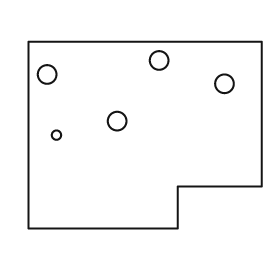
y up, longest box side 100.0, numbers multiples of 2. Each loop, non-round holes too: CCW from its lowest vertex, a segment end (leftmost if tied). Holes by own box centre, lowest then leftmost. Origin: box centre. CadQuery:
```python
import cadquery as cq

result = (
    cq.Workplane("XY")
    .moveTo(-50.0, -40.0)
    .lineTo(14.0, -40.0)
    .lineTo(14.0, -22.0)
    .lineTo(50.0, -22.0)
    .lineTo(50.0, 40.0)
    .lineTo(-50.0, 40.0)
    .close()
    .moveTo(-38.0, 0.0)
    .circle(2.0)
    .moveTo(-12.0, 6.0)
    .circle(4.0)
    .moveTo(34.0, 22.0)
    .circle(4.0)
    .moveTo(-42.0, 26.0)
    .circle(4.0)
    .moveTo(6.0, 32.0)
    .circle(4.0)
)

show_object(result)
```